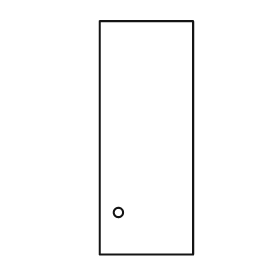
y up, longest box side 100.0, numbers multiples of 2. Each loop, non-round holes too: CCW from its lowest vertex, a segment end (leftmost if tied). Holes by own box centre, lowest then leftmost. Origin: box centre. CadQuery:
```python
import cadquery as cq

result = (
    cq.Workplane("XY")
    .moveTo(-20.0, -50.0)
    .lineTo(20.0, -50.0)
    .lineTo(20.0, 50.0)
    .lineTo(-20.0, 50.0)
    .close()
    .moveTo(-12.0, -32.0)
    .circle(2.0)
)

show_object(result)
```